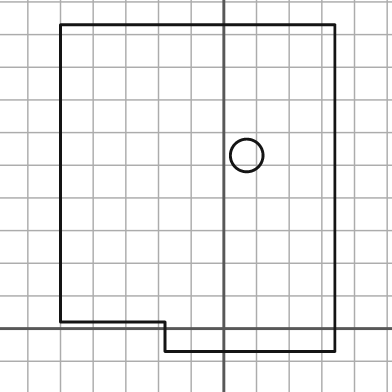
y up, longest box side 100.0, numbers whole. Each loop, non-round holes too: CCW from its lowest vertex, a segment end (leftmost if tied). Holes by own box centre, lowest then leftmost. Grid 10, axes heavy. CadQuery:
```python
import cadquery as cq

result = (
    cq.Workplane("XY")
    .moveTo(-18.0, -7.0)
    .lineTo(34.0, -7.0)
    .lineTo(34.0, 93.0)
    .lineTo(-50.0, 93.0)
    .lineTo(-50.0, 2.0)
    .lineTo(-18.0, 2.0)
    .close()
    .moveTo(7.0, 53.0)
    .circle(5.0)
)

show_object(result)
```